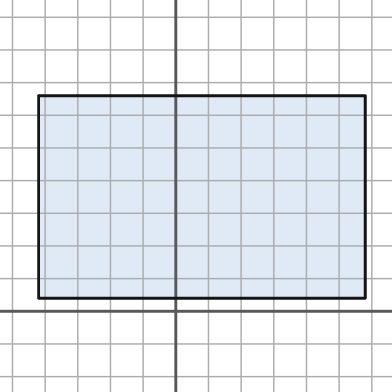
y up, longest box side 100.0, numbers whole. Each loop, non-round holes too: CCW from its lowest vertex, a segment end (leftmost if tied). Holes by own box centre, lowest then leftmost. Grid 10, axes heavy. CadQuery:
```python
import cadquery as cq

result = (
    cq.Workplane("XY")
    .moveTo(-42.0, 4.0)
    .lineTo(58.0, 4.0)
    .lineTo(58.0, 66.0)
    .lineTo(-42.0, 66.0)
    .close()
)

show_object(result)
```